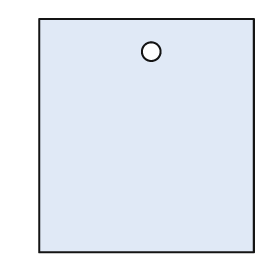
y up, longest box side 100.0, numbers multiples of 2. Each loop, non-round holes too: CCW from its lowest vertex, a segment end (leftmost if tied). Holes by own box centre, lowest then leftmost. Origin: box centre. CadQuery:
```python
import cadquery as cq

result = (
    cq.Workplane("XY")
    .moveTo(-46.0, -50.0)
    .lineTo(46.0, -50.0)
    .lineTo(46.0, 50.0)
    .lineTo(-46.0, 50.0)
    .close()
    .moveTo(2.0, 36.0)
    .circle(4.0)
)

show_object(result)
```